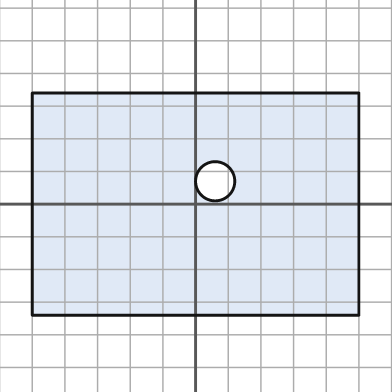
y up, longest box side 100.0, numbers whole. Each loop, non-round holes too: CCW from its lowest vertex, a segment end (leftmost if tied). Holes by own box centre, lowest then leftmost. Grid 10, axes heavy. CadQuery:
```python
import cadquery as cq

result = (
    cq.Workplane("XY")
    .moveTo(-50.0, -34.0)
    .lineTo(50.0, -34.0)
    .lineTo(50.0, 34.0)
    .lineTo(-50.0, 34.0)
    .close()
    .moveTo(6.0, 7.0)
    .circle(6.0)
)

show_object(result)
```